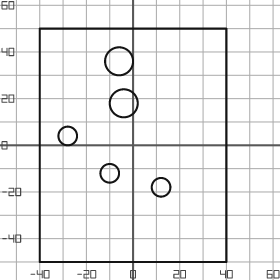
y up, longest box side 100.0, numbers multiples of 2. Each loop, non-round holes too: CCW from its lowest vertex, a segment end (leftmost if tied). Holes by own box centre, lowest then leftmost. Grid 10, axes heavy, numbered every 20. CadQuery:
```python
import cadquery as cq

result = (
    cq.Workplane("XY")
    .moveTo(-40.0, -50.0)
    .lineTo(40.0, -50.0)
    .lineTo(40.0, 50.0)
    .lineTo(-40.0, 50.0)
    .close()
    .moveTo(12.0, -18.0)
    .circle(4.0)
    .moveTo(-10.0, -12.0)
    .circle(4.0)
    .moveTo(-28.0, 4.0)
    .circle(4.0)
    .moveTo(-4.0, 18.0)
    .circle(6.0)
    .moveTo(-6.0, 36.0)
    .circle(6.0)
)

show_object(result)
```